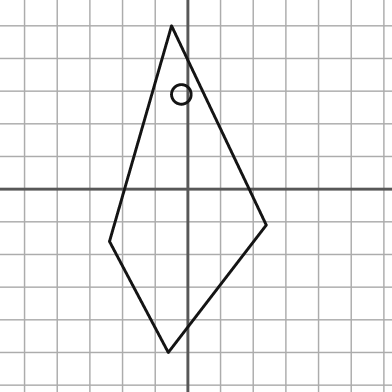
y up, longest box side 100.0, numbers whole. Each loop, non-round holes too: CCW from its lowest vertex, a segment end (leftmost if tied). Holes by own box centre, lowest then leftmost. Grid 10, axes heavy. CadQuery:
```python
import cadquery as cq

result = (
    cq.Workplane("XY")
    .moveTo(-6.0, -50.0)
    .lineTo(24.0, -11.0)
    .lineTo(-5.0, 50.0)
    .lineTo(-24.0, -16.0)
    .close()
    .moveTo(-2.0, 29.0)
    .circle(3.0)
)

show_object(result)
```